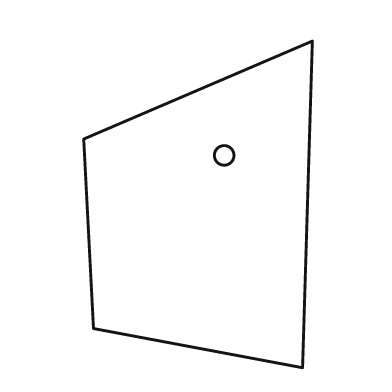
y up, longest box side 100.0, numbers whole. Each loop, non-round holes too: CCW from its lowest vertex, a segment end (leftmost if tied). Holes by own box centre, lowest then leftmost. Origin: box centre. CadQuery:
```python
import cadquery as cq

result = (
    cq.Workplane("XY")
    .moveTo(32.0, -50.0)
    .lineTo(35.0, 50.0)
    .lineTo(-35.0, 20.0)
    .lineTo(-32.0, -38.0)
    .close()
    .moveTo(8.0, 15.0)
    .circle(3.0)
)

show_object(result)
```